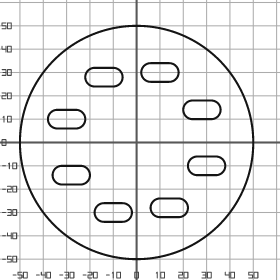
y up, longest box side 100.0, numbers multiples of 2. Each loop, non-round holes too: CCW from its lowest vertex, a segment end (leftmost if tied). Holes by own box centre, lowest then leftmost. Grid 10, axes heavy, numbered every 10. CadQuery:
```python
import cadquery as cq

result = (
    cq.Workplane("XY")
    .moveTo(0.0, 0.0)
    .circle(50.0)
    .moveTo(-14.0, -34.0)
    .lineTo(-6.0, -34.0)
    .threePointArc((-2.0, -30.0), (-6.0, -26.0))
    .lineTo(-14.0, -26.0)
    .threePointArc((-18.0, -30.0), (-14.0, -34.0))
    .close()
    .moveTo(10.0, -32.0)
    .lineTo(18.0, -32.0)
    .threePointArc((22.0, -28.0), (18.0, -24.0))
    .lineTo(10.0, -24.0)
    .threePointArc((6.0, -28.0), (10.0, -32.0))
    .close()
    .moveTo(-32.0, -18.0)
    .lineTo(-24.0, -18.0)
    .threePointArc((-20.0, -14.0), (-24.0, -10.0))
    .lineTo(-32.0, -10.0)
    .threePointArc((-36.0, -14.0), (-32.0, -18.0))
    .close()
    .moveTo(26.0, -14.0)
    .lineTo(34.0, -14.0)
    .threePointArc((38.0, -10.0), (34.0, -6.0))
    .lineTo(26.0, -6.0)
    .threePointArc((22.0, -10.0), (26.0, -14.0))
    .close()
    .moveTo(-34.0, 6.0)
    .lineTo(-26.0, 6.0)
    .threePointArc((-22.0, 10.0), (-26.0, 14.0))
    .lineTo(-34.0, 14.0)
    .threePointArc((-38.0, 10.0), (-34.0, 6.0))
    .close()
    .moveTo(24.0, 10.0)
    .lineTo(32.0, 10.0)
    .threePointArc((36.0, 14.0), (32.0, 18.0))
    .lineTo(24.0, 18.0)
    .threePointArc((20.0, 14.0), (24.0, 10.0))
    .close()
    .moveTo(-18.0, 24.0)
    .lineTo(-10.0, 24.0)
    .threePointArc((-6.0, 28.0), (-10.0, 32.0))
    .lineTo(-18.0, 32.0)
    .threePointArc((-22.0, 28.0), (-18.0, 24.0))
    .close()
    .moveTo(6.0, 26.0)
    .lineTo(14.0, 26.0)
    .threePointArc((18.0, 30.0), (14.0, 34.0))
    .lineTo(6.0, 34.0)
    .threePointArc((2.0, 30.0), (6.0, 26.0))
    .close()
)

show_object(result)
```